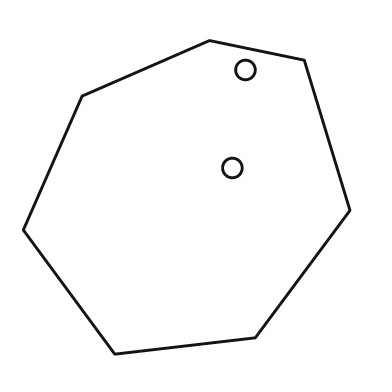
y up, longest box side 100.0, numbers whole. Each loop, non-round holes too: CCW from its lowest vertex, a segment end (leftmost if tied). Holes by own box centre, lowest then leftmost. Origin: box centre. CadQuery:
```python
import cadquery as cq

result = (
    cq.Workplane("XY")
    .moveTo(-22.0, -48.0)
    .lineTo(21.0, -43.0)
    .lineTo(50.0, -4.0)
    .lineTo(36.0, 42.0)
    .lineTo(7.0, 48.0)
    .lineTo(-32.0, 31.0)
    .lineTo(-50.0, -10.0)
    .close()
    .moveTo(14.0, 9.0)
    .circle(3.0)
    .moveTo(18.0, 39.0)
    .circle(3.0)
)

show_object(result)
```